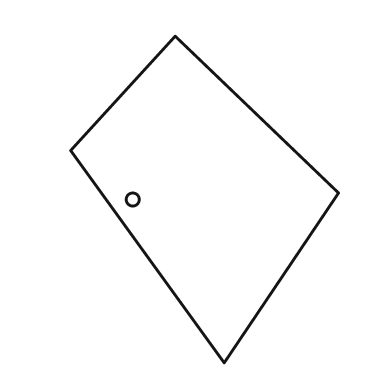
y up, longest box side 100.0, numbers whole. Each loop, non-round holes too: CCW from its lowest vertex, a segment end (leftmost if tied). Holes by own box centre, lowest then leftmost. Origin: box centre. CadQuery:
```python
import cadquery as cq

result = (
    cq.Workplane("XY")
    .moveTo(6.0, -50.0)
    .lineTo(41.0, 2.0)
    .lineTo(-9.0, 50.0)
    .lineTo(-41.0, 15.0)
    .close()
    .moveTo(-22.0, 0.0)
    .circle(2.0)
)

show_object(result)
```